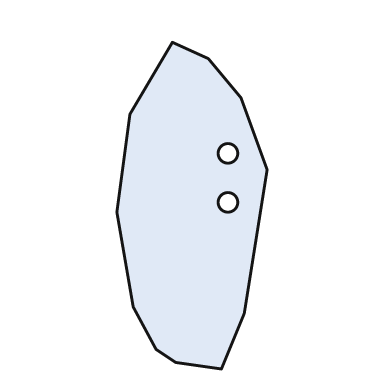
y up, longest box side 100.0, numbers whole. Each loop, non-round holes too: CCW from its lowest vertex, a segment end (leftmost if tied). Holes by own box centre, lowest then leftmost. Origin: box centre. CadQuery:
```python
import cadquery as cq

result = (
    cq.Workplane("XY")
    .moveTo(9.0, -50.0)
    .lineTo(16.0, -33.0)
    .lineTo(23.0, 11.0)
    .lineTo(15.0, 33.0)
    .lineTo(5.0, 45.0)
    .lineTo(-6.0, 50.0)
    .lineTo(-19.0, 28.0)
    .lineTo(-23.0, -2.0)
    .lineTo(-18.0, -31.0)
    .lineTo(-11.0, -44.0)
    .lineTo(-5.0, -48.0)
    .close()
    .moveTo(11.0, 1.0)
    .circle(3.0)
    .moveTo(11.0, 16.0)
    .circle(3.0)
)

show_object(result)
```